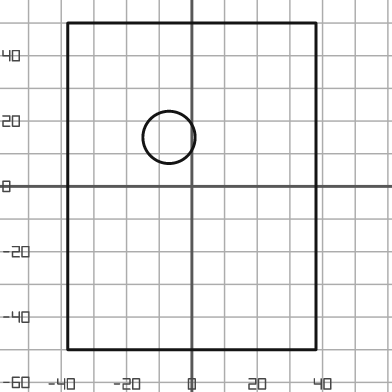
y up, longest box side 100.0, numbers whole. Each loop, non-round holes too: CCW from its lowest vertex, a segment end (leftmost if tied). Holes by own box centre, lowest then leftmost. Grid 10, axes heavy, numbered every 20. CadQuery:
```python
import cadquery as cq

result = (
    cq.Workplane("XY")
    .moveTo(-38.0, -50.0)
    .lineTo(38.0, -50.0)
    .lineTo(38.0, 50.0)
    .lineTo(-38.0, 50.0)
    .close()
    .moveTo(-7.0, 15.0)
    .circle(8.0)
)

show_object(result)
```